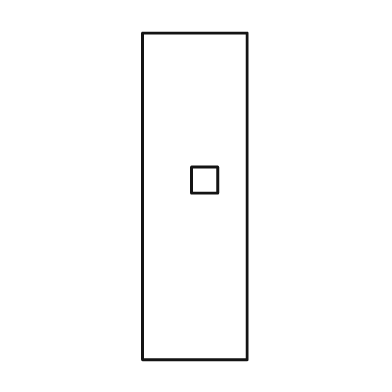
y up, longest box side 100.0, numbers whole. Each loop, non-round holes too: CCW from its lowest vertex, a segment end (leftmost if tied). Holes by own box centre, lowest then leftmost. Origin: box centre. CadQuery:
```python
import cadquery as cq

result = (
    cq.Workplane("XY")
    .moveTo(-16.0, -50.0)
    .lineTo(16.0, -50.0)
    .lineTo(16.0, 50.0)
    .lineTo(-16.0, 50.0)
    .close()
    .moveTo(-1.0, 1.0)
    .lineTo(7.0, 1.0)
    .lineTo(7.0, 9.0)
    .lineTo(-1.0, 9.0)
    .close()
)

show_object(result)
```